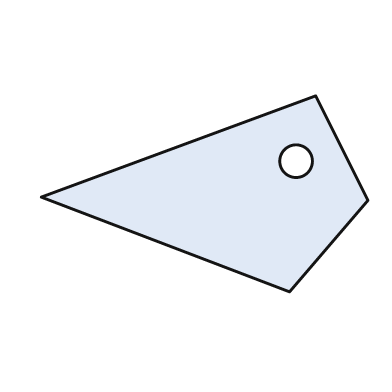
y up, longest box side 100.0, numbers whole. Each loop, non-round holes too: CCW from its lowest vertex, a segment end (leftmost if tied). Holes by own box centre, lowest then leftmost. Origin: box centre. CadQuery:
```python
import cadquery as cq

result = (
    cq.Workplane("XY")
    .moveTo(26.0, -30.0)
    .lineTo(50.0, -2.0)
    .lineTo(34.0, 30.0)
    .lineTo(-50.0, -1.0)
    .close()
    .moveTo(28.0, 10.0)
    .circle(5.0)
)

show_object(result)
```